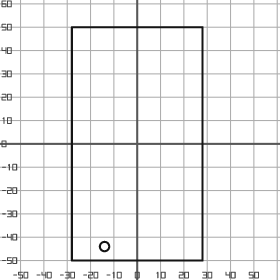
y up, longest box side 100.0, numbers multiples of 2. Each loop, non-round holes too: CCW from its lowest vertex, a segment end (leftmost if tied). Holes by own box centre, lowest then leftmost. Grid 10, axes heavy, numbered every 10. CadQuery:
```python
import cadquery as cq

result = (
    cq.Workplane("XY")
    .moveTo(-28.0, -50.0)
    .lineTo(28.0, -50.0)
    .lineTo(28.0, 50.0)
    .lineTo(-28.0, 50.0)
    .close()
    .moveTo(-14.0, -44.0)
    .circle(2.0)
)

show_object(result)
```